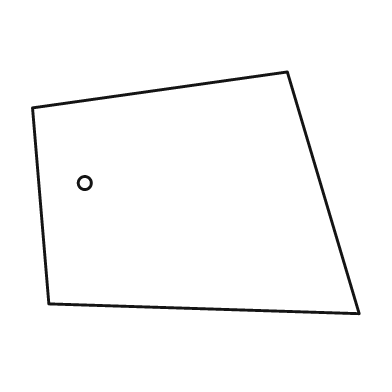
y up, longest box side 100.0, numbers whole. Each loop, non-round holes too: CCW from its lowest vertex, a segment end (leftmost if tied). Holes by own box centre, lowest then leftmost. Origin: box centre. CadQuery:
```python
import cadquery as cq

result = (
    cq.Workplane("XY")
    .moveTo(50.0, -37.0)
    .lineTo(28.0, 37.0)
    .lineTo(-50.0, 26.0)
    .lineTo(-45.0, -34.0)
    .close()
    .moveTo(-34.0, 3.0)
    .circle(2.0)
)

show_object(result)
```